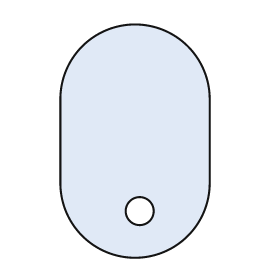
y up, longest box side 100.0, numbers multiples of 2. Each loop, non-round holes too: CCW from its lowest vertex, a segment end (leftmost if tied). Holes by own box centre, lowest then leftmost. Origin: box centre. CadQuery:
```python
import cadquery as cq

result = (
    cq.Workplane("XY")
    .moveTo(-32.0, -18.0)
    .threePointArc((0.0, -50.0), (32.0, -18.0))
    .lineTo(32.0, 18.0)
    .threePointArc((0.0, 50.0), (-32.0, 18.0))
    .close()
    .moveTo(2.0, -30.0)
    .circle(6.0)
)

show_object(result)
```